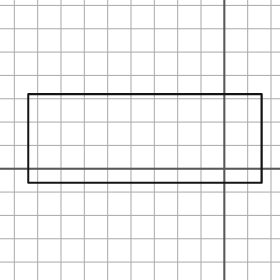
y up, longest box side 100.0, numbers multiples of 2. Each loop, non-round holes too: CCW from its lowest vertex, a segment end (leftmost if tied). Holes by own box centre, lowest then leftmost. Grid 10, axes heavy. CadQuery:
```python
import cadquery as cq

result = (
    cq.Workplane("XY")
    .moveTo(-84.0, -6.0)
    .lineTo(16.0, -6.0)
    .lineTo(16.0, 32.0)
    .lineTo(-84.0, 32.0)
    .close()
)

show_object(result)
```